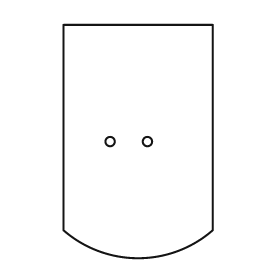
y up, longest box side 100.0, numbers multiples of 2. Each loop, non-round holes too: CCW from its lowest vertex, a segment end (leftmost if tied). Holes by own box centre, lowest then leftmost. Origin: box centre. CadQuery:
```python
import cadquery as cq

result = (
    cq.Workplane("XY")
    .moveTo(-32.0, -38.0)
    .threePointArc((0.0, -50.0), (32.0, -38.0))
    .lineTo(32.0, 50.0)
    .lineTo(-32.0, 50.0)
    .close()
    .moveTo(-12.0, 0.0)
    .circle(2.0)
    .moveTo(4.0, 0.0)
    .circle(2.0)
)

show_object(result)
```